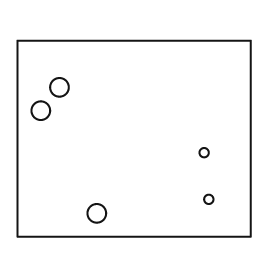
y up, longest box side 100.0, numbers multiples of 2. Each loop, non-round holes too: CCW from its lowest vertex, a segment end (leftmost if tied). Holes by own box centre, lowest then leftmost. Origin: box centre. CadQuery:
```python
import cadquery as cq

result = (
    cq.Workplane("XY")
    .moveTo(-50.0, -42.0)
    .lineTo(50.0, -42.0)
    .lineTo(50.0, 42.0)
    .lineTo(-50.0, 42.0)
    .close()
    .moveTo(-16.0, -32.0)
    .circle(4.0)
    .moveTo(32.0, -26.0)
    .circle(2.0)
    .moveTo(30.0, -6.0)
    .circle(2.0)
    .moveTo(-40.0, 12.0)
    .circle(4.0)
    .moveTo(-32.0, 22.0)
    .circle(4.0)
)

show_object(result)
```